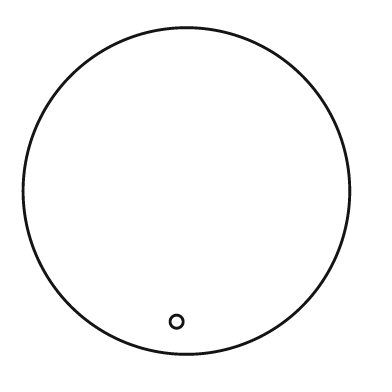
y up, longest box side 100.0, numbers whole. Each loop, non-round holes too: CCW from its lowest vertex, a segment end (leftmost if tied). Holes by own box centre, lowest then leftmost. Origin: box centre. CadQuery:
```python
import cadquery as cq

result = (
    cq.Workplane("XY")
    .moveTo(0.0, 0.0)
    .circle(50.0)
    .moveTo(-3.0, -40.0)
    .circle(2.0)
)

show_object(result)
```